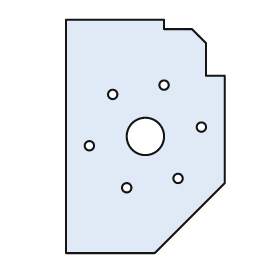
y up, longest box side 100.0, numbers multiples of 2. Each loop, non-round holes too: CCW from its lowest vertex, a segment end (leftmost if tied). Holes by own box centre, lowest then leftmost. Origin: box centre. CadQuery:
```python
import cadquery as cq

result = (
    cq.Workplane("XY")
    .moveTo(-34.0, -50.0)
    .lineTo(4.0, -50.0)
    .lineTo(34.0, -20.0)
    .lineTo(34.0, 26.0)
    .lineTo(26.0, 26.0)
    .lineTo(26.0, 40.0)
    .lineTo(20.0, 46.0)
    .lineTo(8.0, 46.0)
    .lineTo(8.0, 50.0)
    .lineTo(-34.0, 50.0)
    .close()
    .moveTo(-8.0, -22.0)
    .circle(2.0)
    .moveTo(14.0, -18.0)
    .circle(2.0)
    .moveTo(-24.0, -4.0)
    .circle(2.0)
    .moveTo(0.0, 0.0)
    .circle(8.0)
    .moveTo(24.0, 4.0)
    .circle(2.0)
    .moveTo(-14.0, 18.0)
    .circle(2.0)
    .moveTo(8.0, 22.0)
    .circle(2.0)
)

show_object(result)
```